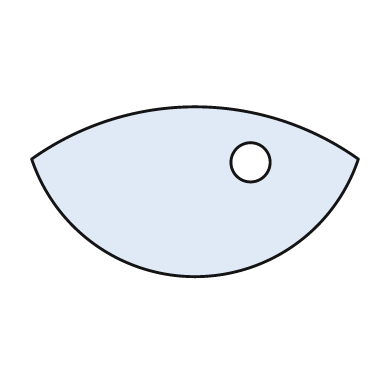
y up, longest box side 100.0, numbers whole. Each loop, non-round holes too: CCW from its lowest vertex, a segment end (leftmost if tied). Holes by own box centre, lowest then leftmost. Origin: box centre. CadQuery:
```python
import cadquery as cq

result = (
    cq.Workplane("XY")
    .moveTo(-50.0, 10.0)
    .threePointArc((0.0, -26.0), (50.0, 10.0))
    .threePointArc((0.0, 26.0), (-50.0, 10.0))
    .close()
    .moveTo(17.0, 9.0)
    .circle(6.0)
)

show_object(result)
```